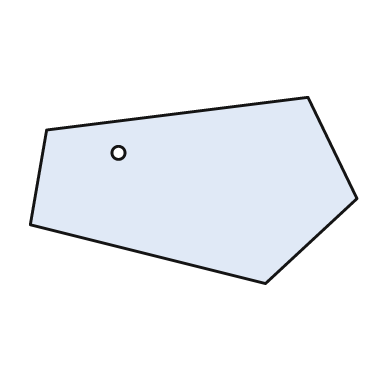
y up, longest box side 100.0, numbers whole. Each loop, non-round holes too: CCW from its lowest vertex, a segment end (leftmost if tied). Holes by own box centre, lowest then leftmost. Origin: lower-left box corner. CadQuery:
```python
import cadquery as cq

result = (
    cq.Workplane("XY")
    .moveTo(72.0, 0.0)
    .lineTo(100.0, 26.0)
    .lineTo(85.0, 57.0)
    .lineTo(5.0, 47.0)
    .lineTo(0.0, 18.0)
    .close()
    .moveTo(27.0, 40.0)
    .circle(2.0)
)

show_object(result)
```